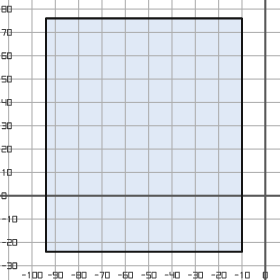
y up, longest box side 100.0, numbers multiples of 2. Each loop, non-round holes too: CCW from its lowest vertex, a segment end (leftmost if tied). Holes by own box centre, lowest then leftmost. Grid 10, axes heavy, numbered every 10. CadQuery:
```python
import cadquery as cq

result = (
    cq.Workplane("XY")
    .moveTo(-94.0, -24.0)
    .lineTo(-10.0, -24.0)
    .lineTo(-10.0, 76.0)
    .lineTo(-94.0, 76.0)
    .close()
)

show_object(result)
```